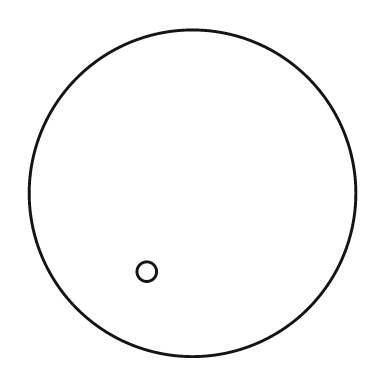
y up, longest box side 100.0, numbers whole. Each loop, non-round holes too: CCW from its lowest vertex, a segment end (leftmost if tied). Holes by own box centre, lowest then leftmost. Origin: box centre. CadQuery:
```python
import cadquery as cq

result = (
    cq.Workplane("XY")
    .moveTo(0.0, 0.0)
    .circle(50.0)
    .moveTo(-14.0, -24.0)
    .circle(3.0)
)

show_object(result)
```